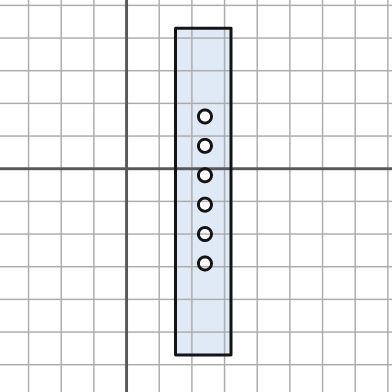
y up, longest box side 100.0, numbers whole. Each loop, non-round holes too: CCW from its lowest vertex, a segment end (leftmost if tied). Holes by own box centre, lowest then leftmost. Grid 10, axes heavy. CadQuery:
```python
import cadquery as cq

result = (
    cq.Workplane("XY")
    .moveTo(15.0, -57.0)
    .lineTo(32.0, -57.0)
    .lineTo(32.0, 43.0)
    .lineTo(15.0, 43.0)
    .close()
    .moveTo(24.0, -29.0)
    .circle(2.0)
    .moveTo(24.0, -20.0)
    .circle(2.0)
    .moveTo(24.0, -11.0)
    .circle(2.0)
    .moveTo(24.0, -2.0)
    .circle(2.0)
    .moveTo(24.0, 7.0)
    .circle(2.0)
    .moveTo(24.0, 16.0)
    .circle(2.0)
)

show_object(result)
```